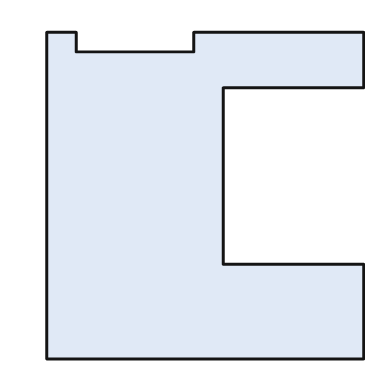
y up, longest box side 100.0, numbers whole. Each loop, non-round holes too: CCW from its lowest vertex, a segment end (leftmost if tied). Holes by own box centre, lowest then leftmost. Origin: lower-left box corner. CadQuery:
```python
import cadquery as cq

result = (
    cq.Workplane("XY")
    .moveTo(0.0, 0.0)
    .lineTo(97.0, 0.0)
    .lineTo(97.0, 29.0)
    .lineTo(54.0, 29.0)
    .lineTo(54.0, 83.0)
    .lineTo(97.0, 83.0)
    .lineTo(97.0, 100.0)
    .lineTo(45.0, 100.0)
    .lineTo(45.0, 94.0)
    .lineTo(9.0, 94.0)
    .lineTo(9.0, 100.0)
    .lineTo(0.0, 100.0)
    .close()
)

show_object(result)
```